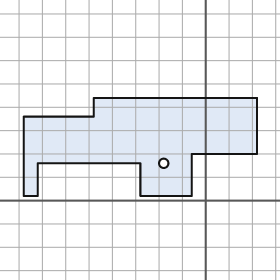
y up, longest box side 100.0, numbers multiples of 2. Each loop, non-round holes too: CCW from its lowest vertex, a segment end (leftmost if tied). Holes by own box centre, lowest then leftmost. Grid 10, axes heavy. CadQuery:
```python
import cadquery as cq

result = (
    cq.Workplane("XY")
    .moveTo(-78.0, 2.0)
    .lineTo(-72.0, 2.0)
    .lineTo(-72.0, 16.0)
    .lineTo(-28.0, 16.0)
    .lineTo(-28.0, 2.0)
    .lineTo(-6.0, 2.0)
    .lineTo(-6.0, 20.0)
    .lineTo(22.0, 20.0)
    .lineTo(22.0, 44.0)
    .lineTo(-48.0, 44.0)
    .lineTo(-48.0, 36.0)
    .lineTo(-78.0, 36.0)
    .close()
    .moveTo(-18.0, 16.0)
    .circle(2.0)
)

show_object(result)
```